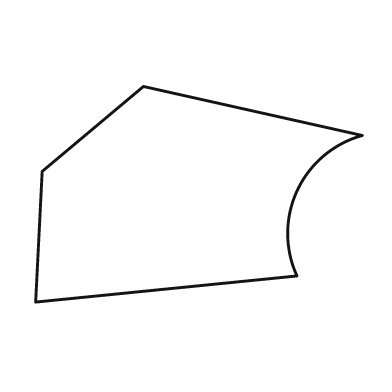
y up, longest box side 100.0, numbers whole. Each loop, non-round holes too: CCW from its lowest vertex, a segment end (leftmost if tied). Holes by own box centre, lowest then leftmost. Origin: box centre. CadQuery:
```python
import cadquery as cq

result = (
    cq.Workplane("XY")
    .moveTo(-50.0, -33.0)
    .lineTo(30.0, -25.0)
    .threePointArc((30.0, 1.0), (50.0, 18.0))
    .lineTo(-17.0, 33.0)
    .lineTo(-48.0, 7.0)
    .close()
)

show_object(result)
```